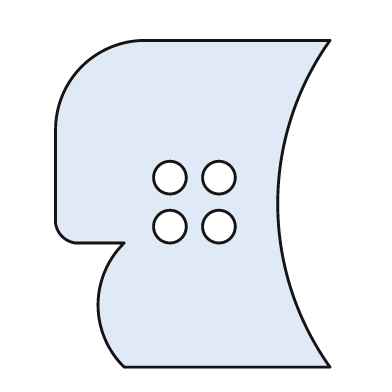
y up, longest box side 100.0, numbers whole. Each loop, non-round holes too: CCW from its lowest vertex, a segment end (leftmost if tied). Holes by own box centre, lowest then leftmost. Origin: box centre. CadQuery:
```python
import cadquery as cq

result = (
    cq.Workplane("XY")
    .moveTo(-21.0, -50.0)
    .lineTo(42.0, -50.0)
    .threePointArc((26.0, 0.0), (42.0, 50.0))
    .lineTo(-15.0, 50.0)
    .threePointArc((-34.0, 42.0), (-42.0, 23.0))
    .lineTo(-42.0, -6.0)
    .threePointArc((-40.0, -10.0), (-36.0, -12.0))
    .lineTo(-21.0, -12.0)
    .threePointArc((-29.0, -31.0), (-21.0, -50.0))
    .close()
    .moveTo(-7.0, -7.0)
    .circle(5.0)
    .moveTo(8.0, -7.0)
    .circle(5.0)
    .moveTo(-7.0, 8.0)
    .circle(5.0)
    .moveTo(8.0, 8.0)
    .circle(5.0)
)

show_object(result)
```